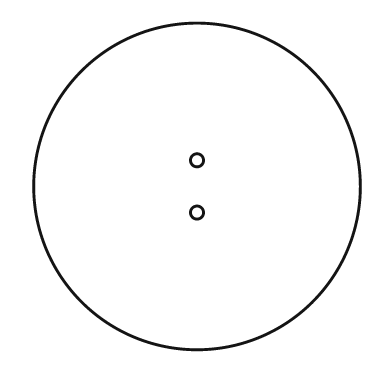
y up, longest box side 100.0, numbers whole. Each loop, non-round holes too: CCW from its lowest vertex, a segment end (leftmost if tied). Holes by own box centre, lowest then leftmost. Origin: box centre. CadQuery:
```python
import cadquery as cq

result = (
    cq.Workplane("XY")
    .moveTo(0.0, 0.0)
    .circle(50.0)
    .moveTo(0.0, -8.0)
    .circle(2.0)
    .moveTo(0.0, 8.0)
    .circle(2.0)
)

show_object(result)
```